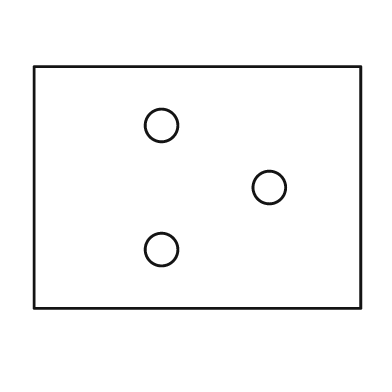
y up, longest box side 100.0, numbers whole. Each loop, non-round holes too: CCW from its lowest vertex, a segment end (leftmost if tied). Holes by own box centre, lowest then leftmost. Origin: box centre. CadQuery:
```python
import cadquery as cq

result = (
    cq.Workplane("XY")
    .moveTo(-50.0, -37.0)
    .lineTo(50.0, -37.0)
    .lineTo(50.0, 37.0)
    .lineTo(-50.0, 37.0)
    .close()
    .moveTo(-11.0, -19.0)
    .circle(5.0)
    .moveTo(22.0, 0.0)
    .circle(5.0)
    .moveTo(-11.0, 19.0)
    .circle(5.0)
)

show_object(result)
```